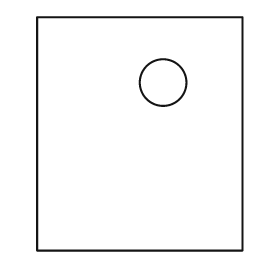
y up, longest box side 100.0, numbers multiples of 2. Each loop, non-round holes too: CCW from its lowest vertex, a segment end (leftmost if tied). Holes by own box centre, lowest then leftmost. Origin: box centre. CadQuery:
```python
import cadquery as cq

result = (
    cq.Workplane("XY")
    .moveTo(-44.0, -50.0)
    .lineTo(44.0, -50.0)
    .lineTo(44.0, 50.0)
    .lineTo(-44.0, 50.0)
    .close()
    .moveTo(10.0, 22.0)
    .circle(10.0)
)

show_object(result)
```